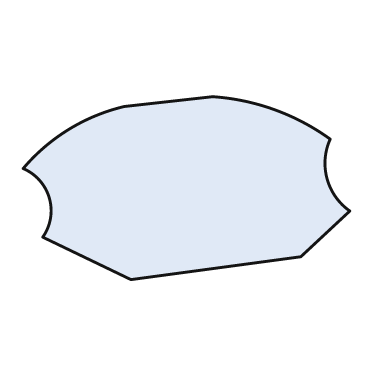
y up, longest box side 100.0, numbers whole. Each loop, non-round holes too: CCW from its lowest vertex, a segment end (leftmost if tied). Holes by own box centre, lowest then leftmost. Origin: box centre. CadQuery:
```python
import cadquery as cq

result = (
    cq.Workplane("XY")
    .moveTo(-17.0, -28.0)
    .lineTo(35.0, -21.0)
    .lineTo(50.0, -7.0)
    .threePointArc((43.0, 3.0), (44.0, 15.0))
    .threePointArc((27.0, 24.0), (8.0, 28.0))
    .lineTo(-19.0, 25.0)
    .threePointArc((-36.0, 18.0), (-50.0, 6.0))
    .threePointArc((-42.0, -3.0), (-44.0, -15.0))
    .close()
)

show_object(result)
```